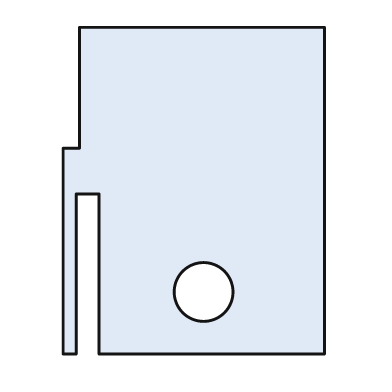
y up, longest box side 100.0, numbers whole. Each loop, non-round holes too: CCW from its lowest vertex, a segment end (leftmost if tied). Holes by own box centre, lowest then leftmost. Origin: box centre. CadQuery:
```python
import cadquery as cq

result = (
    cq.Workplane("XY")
    .moveTo(-40.0, -50.0)
    .lineTo(-36.0, -50.0)
    .lineTo(-36.0, -1.0)
    .lineTo(-29.0, -1.0)
    .lineTo(-29.0, -50.0)
    .lineTo(40.0, -50.0)
    .lineTo(40.0, 50.0)
    .lineTo(-35.0, 50.0)
    .lineTo(-35.0, 13.0)
    .lineTo(-40.0, 13.0)
    .close()
    .moveTo(3.0, -31.0)
    .circle(9.0)
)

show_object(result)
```